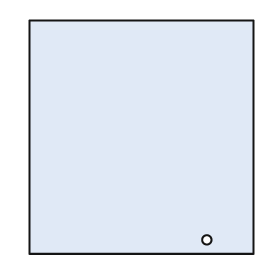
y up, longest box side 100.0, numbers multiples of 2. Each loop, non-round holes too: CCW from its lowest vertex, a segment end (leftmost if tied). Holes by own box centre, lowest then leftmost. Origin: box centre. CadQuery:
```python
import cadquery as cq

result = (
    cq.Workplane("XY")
    .moveTo(-48.0, -50.0)
    .lineTo(48.0, -50.0)
    .lineTo(48.0, 50.0)
    .lineTo(-48.0, 50.0)
    .close()
    .moveTo(28.0, -44.0)
    .circle(2.0)
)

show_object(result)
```